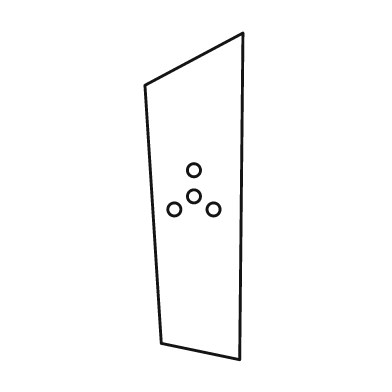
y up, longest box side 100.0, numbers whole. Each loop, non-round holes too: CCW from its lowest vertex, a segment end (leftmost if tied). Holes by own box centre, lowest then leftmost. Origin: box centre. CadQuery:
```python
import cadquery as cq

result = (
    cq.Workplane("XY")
    .moveTo(14.0, -50.0)
    .lineTo(15.0, 50.0)
    .lineTo(-15.0, 34.0)
    .lineTo(-10.0, -45.0)
    .close()
    .moveTo(-6.0, -4.0)
    .circle(2.0)
    .moveTo(6.0, -4.0)
    .circle(2.0)
    .moveTo(0.0, 0.0)
    .circle(2.0)
    .moveTo(0.0, 8.0)
    .circle(2.0)
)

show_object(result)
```